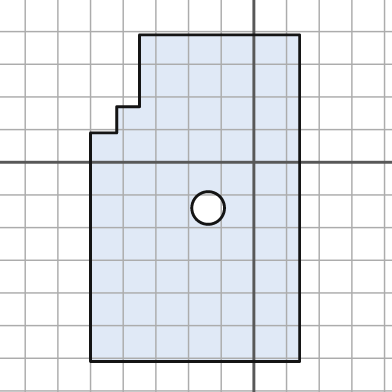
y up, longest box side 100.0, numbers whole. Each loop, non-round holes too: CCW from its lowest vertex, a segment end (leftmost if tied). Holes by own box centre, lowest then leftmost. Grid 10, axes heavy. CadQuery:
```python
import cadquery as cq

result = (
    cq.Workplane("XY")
    .moveTo(-50.0, -61.0)
    .lineTo(14.0, -61.0)
    .lineTo(14.0, 39.0)
    .lineTo(-35.0, 39.0)
    .lineTo(-35.0, 17.0)
    .lineTo(-42.0, 17.0)
    .lineTo(-42.0, 9.0)
    .lineTo(-50.0, 9.0)
    .close()
    .moveTo(-14.0, -14.0)
    .circle(5.0)
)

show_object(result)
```